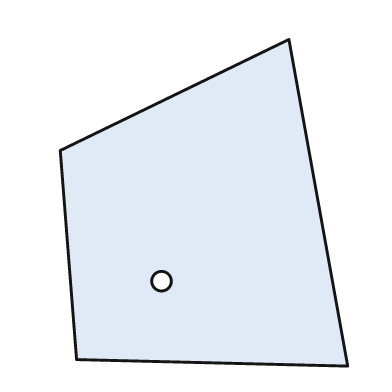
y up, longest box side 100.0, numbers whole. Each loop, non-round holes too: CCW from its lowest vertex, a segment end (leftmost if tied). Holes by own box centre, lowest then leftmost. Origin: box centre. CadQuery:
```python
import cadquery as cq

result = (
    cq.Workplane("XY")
    .moveTo(44.0, -50.0)
    .lineTo(26.0, 50.0)
    .lineTo(-44.0, 16.0)
    .lineTo(-39.0, -48.0)
    .close()
    .moveTo(-13.0, -24.0)
    .circle(3.0)
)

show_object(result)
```